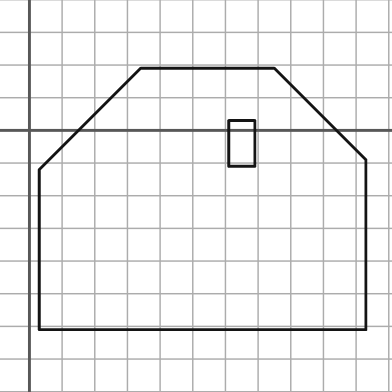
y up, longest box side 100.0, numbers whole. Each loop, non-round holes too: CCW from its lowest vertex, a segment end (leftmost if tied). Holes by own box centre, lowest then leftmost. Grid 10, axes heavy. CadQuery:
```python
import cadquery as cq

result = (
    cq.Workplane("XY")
    .moveTo(3.0, -61.0)
    .lineTo(103.0, -61.0)
    .lineTo(103.0, -9.0)
    .lineTo(75.0, 19.0)
    .lineTo(34.0, 19.0)
    .lineTo(3.0, -12.0)
    .close()
    .moveTo(61.0, -11.0)
    .lineTo(69.0, -11.0)
    .lineTo(69.0, 3.0)
    .lineTo(61.0, 3.0)
    .close()
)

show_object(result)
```